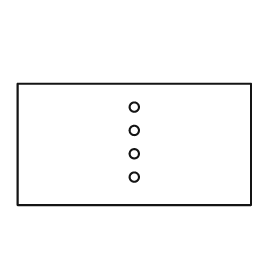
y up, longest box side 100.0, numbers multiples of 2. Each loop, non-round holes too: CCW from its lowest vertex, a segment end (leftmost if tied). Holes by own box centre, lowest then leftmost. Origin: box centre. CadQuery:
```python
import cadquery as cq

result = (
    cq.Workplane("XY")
    .moveTo(-50.0, -26.0)
    .lineTo(50.0, -26.0)
    .lineTo(50.0, 26.0)
    .lineTo(-50.0, 26.0)
    .close()
    .moveTo(0.0, -14.0)
    .circle(2.0)
    .moveTo(0.0, -4.0)
    .circle(2.0)
    .moveTo(0.0, 6.0)
    .circle(2.0)
    .moveTo(0.0, 16.0)
    .circle(2.0)
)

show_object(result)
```